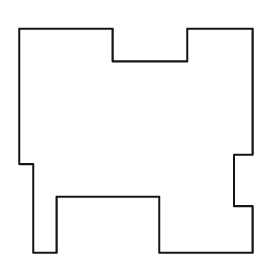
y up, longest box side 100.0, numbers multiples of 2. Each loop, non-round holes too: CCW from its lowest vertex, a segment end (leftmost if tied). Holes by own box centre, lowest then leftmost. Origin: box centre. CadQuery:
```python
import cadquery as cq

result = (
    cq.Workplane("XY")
    .moveTo(-44.0, -48.0)
    .lineTo(-34.0, -48.0)
    .lineTo(-34.0, -24.0)
    .lineTo(10.0, -24.0)
    .lineTo(10.0, -48.0)
    .lineTo(50.0, -48.0)
    .lineTo(50.0, -28.0)
    .lineTo(42.0, -28.0)
    .lineTo(42.0, -6.0)
    .lineTo(50.0, -6.0)
    .lineTo(50.0, 48.0)
    .lineTo(22.0, 48.0)
    .lineTo(22.0, 34.0)
    .lineTo(-10.0, 34.0)
    .lineTo(-10.0, 48.0)
    .lineTo(-50.0, 48.0)
    .lineTo(-50.0, -10.0)
    .lineTo(-44.0, -10.0)
    .close()
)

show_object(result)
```